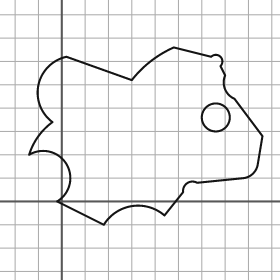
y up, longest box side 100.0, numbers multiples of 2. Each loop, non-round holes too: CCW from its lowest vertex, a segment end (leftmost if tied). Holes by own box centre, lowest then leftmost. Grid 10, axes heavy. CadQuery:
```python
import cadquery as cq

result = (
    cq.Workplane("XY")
    .moveTo(18.0, -10.0)
    .threePointArc((30.0, -2.0), (44.0, -6.0))
    .lineTo(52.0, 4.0)
    .threePointArc((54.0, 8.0), (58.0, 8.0))
    .lineTo(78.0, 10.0)
    .threePointArc((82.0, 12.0), (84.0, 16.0))
    .lineTo(86.0, 28.0)
    .lineTo(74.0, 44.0)
    .threePointArc((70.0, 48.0), (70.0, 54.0))
    .lineTo(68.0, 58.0)
    .threePointArc((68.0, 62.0), (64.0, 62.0))
    .lineTo(48.0, 66.0)
    .threePointArc((38.0, 60.0), (30.0, 52.0))
    .lineTo(2.0, 62.0)
    .threePointArc((-10.0, 50.0), (-4.0, 34.0))
    .threePointArc((-10.0, 28.0), (-14.0, 20.0))
    .threePointArc((2.0, 16.0), (-2.0, 0.0))
    .close()
    .moveTo(66.0, 36.0)
    .circle(6.0)
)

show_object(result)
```